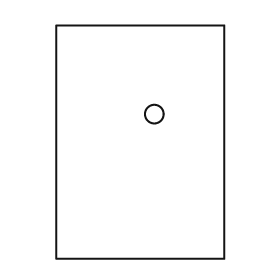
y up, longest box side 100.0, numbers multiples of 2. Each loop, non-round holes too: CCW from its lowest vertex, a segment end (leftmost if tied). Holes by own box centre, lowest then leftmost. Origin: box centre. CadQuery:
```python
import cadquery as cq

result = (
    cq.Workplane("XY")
    .moveTo(-36.0, -50.0)
    .lineTo(36.0, -50.0)
    .lineTo(36.0, 50.0)
    .lineTo(-36.0, 50.0)
    .close()
    .moveTo(6.0, 12.0)
    .circle(4.0)
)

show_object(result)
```